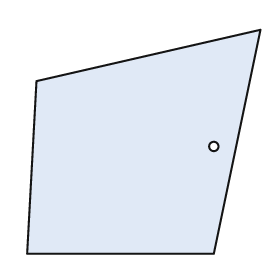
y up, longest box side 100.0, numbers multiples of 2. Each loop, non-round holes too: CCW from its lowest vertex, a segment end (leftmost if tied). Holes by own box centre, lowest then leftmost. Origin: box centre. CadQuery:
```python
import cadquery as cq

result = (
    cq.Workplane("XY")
    .moveTo(-50.0, -48.0)
    .lineTo(30.0, -48.0)
    .lineTo(50.0, 48.0)
    .lineTo(-46.0, 26.0)
    .close()
    .moveTo(30.0, -2.0)
    .circle(2.0)
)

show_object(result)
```